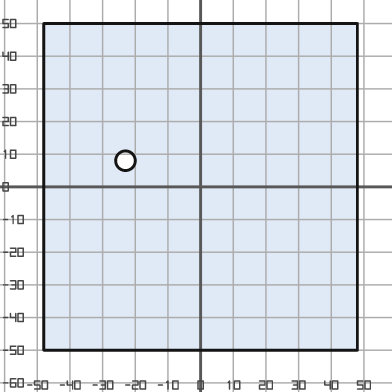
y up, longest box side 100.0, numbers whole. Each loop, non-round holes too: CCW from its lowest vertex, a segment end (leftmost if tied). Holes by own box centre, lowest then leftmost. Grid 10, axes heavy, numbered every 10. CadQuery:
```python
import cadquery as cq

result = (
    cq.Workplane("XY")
    .moveTo(-48.0, -50.0)
    .lineTo(48.0, -50.0)
    .lineTo(48.0, 50.0)
    .lineTo(-48.0, 50.0)
    .close()
    .moveTo(-23.0, 8.0)
    .circle(3.0)
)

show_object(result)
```